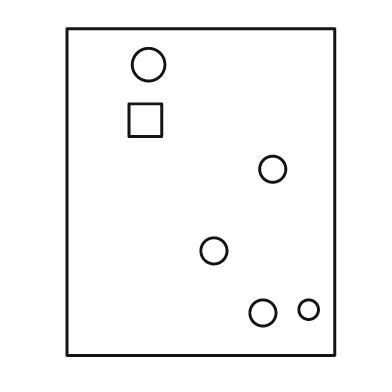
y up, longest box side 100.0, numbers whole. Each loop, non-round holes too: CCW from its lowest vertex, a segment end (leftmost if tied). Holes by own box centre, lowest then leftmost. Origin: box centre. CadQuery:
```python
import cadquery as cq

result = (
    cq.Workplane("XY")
    .moveTo(-41.0, -50.0)
    .lineTo(41.0, -50.0)
    .lineTo(41.0, 50.0)
    .lineTo(-41.0, 50.0)
    .close()
    .moveTo(19.0, -37.0)
    .circle(4.0)
    .moveTo(33.0, -36.0)
    .circle(3.0)
    .moveTo(4.0, -18.0)
    .circle(4.0)
    .moveTo(22.0, 7.0)
    .circle(4.0)
    .moveTo(-22.0, 17.0)
    .lineTo(-12.0, 17.0)
    .lineTo(-12.0, 27.0)
    .lineTo(-22.0, 27.0)
    .close()
    .moveTo(-16.0, 39.0)
    .circle(5.0)
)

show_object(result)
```